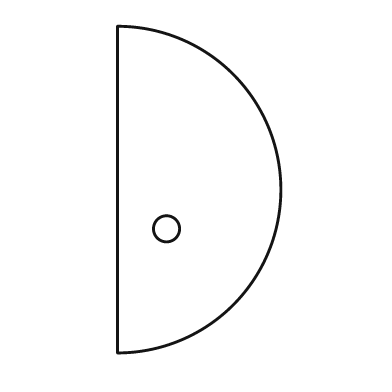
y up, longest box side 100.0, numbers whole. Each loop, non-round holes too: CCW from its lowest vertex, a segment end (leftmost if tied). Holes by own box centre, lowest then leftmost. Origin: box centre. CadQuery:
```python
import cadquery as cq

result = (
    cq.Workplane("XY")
    .moveTo(-25.0, -50.0)
    .threePointArc((25.0, 0.0), (-25.0, 50.0))
    .close()
    .moveTo(-10.0, -12.0)
    .circle(4.0)
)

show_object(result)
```